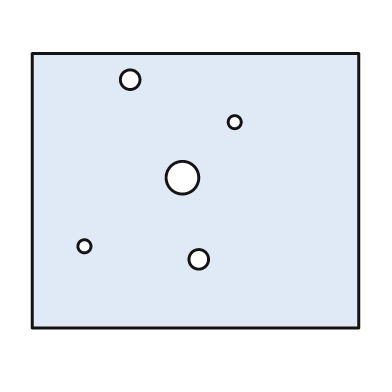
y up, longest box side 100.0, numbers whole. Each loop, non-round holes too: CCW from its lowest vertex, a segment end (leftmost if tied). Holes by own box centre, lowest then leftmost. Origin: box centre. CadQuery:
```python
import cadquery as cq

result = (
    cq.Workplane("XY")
    .moveTo(-50.0, -42.0)
    .lineTo(50.0, -42.0)
    .lineTo(50.0, 42.0)
    .lineTo(-50.0, 42.0)
    .close()
    .moveTo(1.0, -21.0)
    .circle(3.0)
    .moveTo(-34.0, -17.0)
    .circle(2.0)
    .moveTo(-4.0, 4.0)
    .circle(5.0)
    .moveTo(12.0, 21.0)
    .circle(2.0)
    .moveTo(-20.0, 34.0)
    .circle(3.0)
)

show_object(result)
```